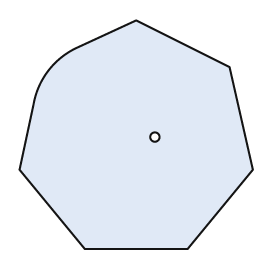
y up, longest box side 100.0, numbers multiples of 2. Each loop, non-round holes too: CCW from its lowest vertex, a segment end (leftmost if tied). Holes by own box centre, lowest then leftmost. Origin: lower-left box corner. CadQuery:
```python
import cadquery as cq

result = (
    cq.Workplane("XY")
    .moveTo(28.0, 0.0)
    .lineTo(72.0, 0.0)
    .lineTo(100.0, 34.0)
    .lineTo(90.0, 78.0)
    .lineTo(50.0, 98.0)
    .lineTo(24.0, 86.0)
    .threePointArc((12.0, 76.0), (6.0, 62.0))
    .lineTo(0.0, 34.0)
    .close()
    .moveTo(58.0, 48.0)
    .circle(2.0)
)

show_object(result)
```